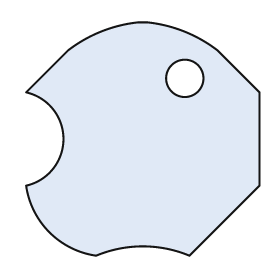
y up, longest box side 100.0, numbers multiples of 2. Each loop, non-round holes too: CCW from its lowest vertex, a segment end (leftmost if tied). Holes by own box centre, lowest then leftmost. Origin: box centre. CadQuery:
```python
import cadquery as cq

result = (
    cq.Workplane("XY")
    .moveTo(-20.0, -50.0)
    .threePointArc((0.0, -46.0), (20.0, -50.0))
    .lineTo(50.0, -20.0)
    .lineTo(50.0, 20.0)
    .lineTo(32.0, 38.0)
    .threePointArc((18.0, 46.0), (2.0, 50.0))
    .lineTo(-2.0, 50.0)
    .threePointArc((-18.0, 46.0), (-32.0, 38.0))
    .lineTo(-50.0, 20.0)
    .threePointArc((-34.0, 0.0), (-50.0, -20.0))
    .threePointArc((-40.0, -40.0), (-20.0, -50.0))
    .close()
    .moveTo(18.0, 26.0)
    .circle(8.0)
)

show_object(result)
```